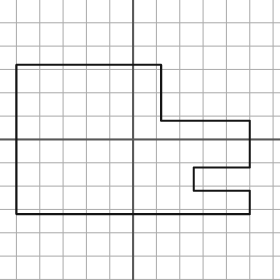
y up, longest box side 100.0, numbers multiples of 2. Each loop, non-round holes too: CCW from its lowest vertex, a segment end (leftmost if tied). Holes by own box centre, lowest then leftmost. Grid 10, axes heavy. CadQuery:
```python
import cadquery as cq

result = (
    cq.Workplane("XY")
    .moveTo(-50.0, -32.0)
    .lineTo(50.0, -32.0)
    .lineTo(50.0, -22.0)
    .lineTo(26.0, -22.0)
    .lineTo(26.0, -12.0)
    .lineTo(50.0, -12.0)
    .lineTo(50.0, 8.0)
    .lineTo(12.0, 8.0)
    .lineTo(12.0, 32.0)
    .lineTo(-50.0, 32.0)
    .close()
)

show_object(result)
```